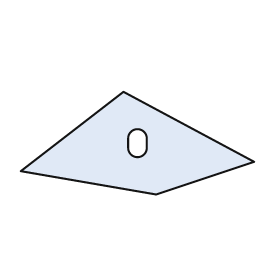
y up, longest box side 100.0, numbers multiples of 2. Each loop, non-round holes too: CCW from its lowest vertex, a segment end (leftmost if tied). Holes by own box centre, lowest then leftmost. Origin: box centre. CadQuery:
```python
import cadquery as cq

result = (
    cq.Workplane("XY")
    .moveTo(8.0, -22.0)
    .lineTo(50.0, -8.0)
    .lineTo(-6.0, 22.0)
    .lineTo(-50.0, -12.0)
    .close()
    .moveTo(-4.0, -2.0)
    .threePointArc((0.0, -6.0), (4.0, -2.0))
    .lineTo(4.0, 2.0)
    .threePointArc((0.0, 6.0), (-4.0, 2.0))
    .close()
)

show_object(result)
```